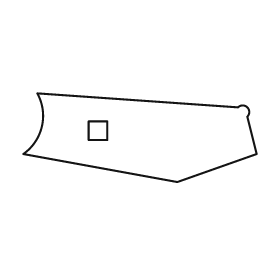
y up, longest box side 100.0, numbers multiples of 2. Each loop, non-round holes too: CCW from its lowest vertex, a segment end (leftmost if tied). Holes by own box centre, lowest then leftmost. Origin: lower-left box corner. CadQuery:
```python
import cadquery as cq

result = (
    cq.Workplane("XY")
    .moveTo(66.0, 0.0)
    .lineTo(100.0, 12.0)
    .lineTo(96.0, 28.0)
    .threePointArc((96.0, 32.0), (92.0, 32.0))
    .lineTo(6.0, 38.0)
    .threePointArc((8.0, 24.0), (0.0, 12.0))
    .close()
    .moveTo(28.0, 18.0)
    .lineTo(36.0, 18.0)
    .lineTo(36.0, 26.0)
    .lineTo(28.0, 26.0)
    .close()
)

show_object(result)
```